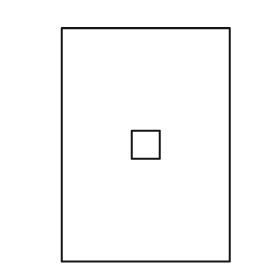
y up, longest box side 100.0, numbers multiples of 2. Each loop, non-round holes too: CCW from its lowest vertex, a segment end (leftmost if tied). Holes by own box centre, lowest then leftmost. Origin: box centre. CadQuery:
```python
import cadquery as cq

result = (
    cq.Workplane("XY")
    .moveTo(-36.0, -50.0)
    .lineTo(36.0, -50.0)
    .lineTo(36.0, 50.0)
    .lineTo(-36.0, 50.0)
    .close()
    .moveTo(-6.0, -6.0)
    .lineTo(6.0, -6.0)
    .lineTo(6.0, 6.0)
    .lineTo(-6.0, 6.0)
    .close()
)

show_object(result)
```